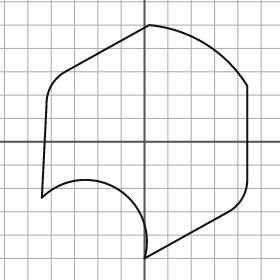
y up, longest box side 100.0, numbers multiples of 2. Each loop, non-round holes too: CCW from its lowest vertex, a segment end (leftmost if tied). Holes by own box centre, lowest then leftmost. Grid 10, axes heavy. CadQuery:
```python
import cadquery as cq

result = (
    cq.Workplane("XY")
    .moveTo(0.0, -50.0)
    .lineTo(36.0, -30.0)
    .threePointArc((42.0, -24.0), (44.0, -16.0))
    .lineTo(44.0, 24.0)
    .threePointArc((26.0, 42.0), (2.0, 50.0))
    .lineTo(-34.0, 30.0)
    .threePointArc((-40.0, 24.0), (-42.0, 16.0))
    .lineTo(-44.0, -24.0)
    .threePointArc((-12.0, -20.0), (0.0, -50.0))
    .close()
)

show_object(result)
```